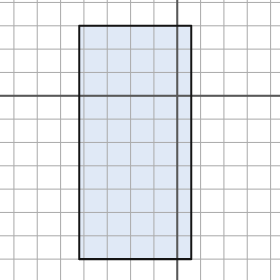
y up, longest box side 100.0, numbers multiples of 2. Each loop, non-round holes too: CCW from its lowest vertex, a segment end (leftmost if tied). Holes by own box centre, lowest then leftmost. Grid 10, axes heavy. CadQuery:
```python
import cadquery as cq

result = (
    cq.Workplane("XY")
    .moveTo(-42.0, -70.0)
    .lineTo(6.0, -70.0)
    .lineTo(6.0, 30.0)
    .lineTo(-42.0, 30.0)
    .close()
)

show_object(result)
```